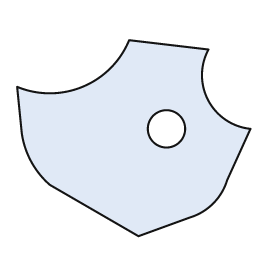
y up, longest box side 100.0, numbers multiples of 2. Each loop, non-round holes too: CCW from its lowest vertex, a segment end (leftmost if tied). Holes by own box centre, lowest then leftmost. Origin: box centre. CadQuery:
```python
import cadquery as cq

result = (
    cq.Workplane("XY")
    .moveTo(2.0, -42.0)
    .lineTo(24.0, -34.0)
    .threePointArc((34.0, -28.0), (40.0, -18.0))
    .lineTo(50.0, 4.0)
    .threePointArc((32.0, 16.0), (32.0, 38.0))
    .lineTo(-2.0, 42.0)
    .threePointArc((-22.0, 22.0), (-50.0, 22.0))
    .lineTo(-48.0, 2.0)
    .threePointArc((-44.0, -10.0), (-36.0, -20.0))
    .close()
    .moveTo(14.0, 4.0)
    .circle(8.0)
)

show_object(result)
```